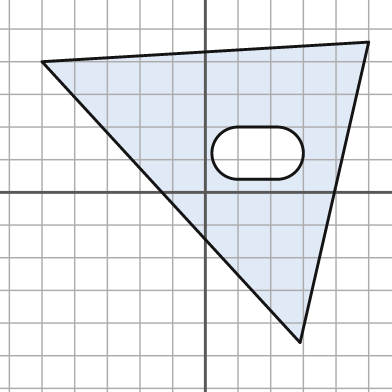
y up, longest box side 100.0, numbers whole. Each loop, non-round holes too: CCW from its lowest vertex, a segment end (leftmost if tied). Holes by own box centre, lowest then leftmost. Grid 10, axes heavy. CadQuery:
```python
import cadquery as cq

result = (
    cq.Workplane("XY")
    .moveTo(29.0, -46.0)
    .lineTo(50.0, 46.0)
    .lineTo(-50.0, 40.0)
    .close()
    .moveTo(10.0, 4.0)
    .lineTo(22.0, 4.0)
    .threePointArc((30.0, 12.0), (22.0, 20.0))
    .lineTo(10.0, 20.0)
    .threePointArc((2.0, 12.0), (10.0, 4.0))
    .close()
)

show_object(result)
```